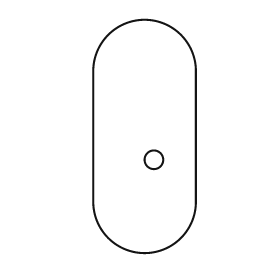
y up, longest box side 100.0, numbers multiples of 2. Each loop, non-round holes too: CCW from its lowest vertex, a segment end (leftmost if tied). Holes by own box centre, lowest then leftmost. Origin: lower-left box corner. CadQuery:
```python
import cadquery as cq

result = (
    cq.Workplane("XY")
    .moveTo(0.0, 22.0)
    .threePointArc((22.0, 0.0), (44.0, 22.0))
    .lineTo(44.0, 78.0)
    .threePointArc((22.0, 100.0), (0.0, 78.0))
    .close()
    .moveTo(26.0, 40.0)
    .circle(4.0)
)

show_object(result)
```